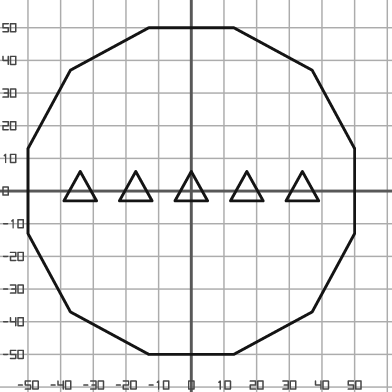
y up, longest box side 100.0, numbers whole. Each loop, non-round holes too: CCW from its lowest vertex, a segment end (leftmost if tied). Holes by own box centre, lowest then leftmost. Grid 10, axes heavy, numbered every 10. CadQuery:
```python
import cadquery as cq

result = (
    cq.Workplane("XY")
    .moveTo(-13.0, -50.0)
    .lineTo(13.0, -50.0)
    .lineTo(37.0, -37.0)
    .lineTo(50.0, -13.0)
    .lineTo(50.0, 13.0)
    .lineTo(37.0, 37.0)
    .lineTo(13.0, 50.0)
    .lineTo(-13.0, 50.0)
    .lineTo(-37.0, 37.0)
    .lineTo(-50.0, 13.0)
    .lineTo(-50.0, -13.0)
    .lineTo(-37.0, -37.0)
    .close()
    .moveTo(-39.0, -3.0)
    .lineTo(-29.0, -3.0)
    .lineTo(-34.0, 6.0)
    .close()
    .moveTo(-22.0, -3.0)
    .lineTo(-12.0, -3.0)
    .lineTo(-17.0, 6.0)
    .close()
    .moveTo(-5.0, -3.0)
    .lineTo(5.0, -3.0)
    .lineTo(0.0, 6.0)
    .close()
    .moveTo(12.0, -3.0)
    .lineTo(22.0, -3.0)
    .lineTo(17.0, 6.0)
    .close()
    .moveTo(29.0, -3.0)
    .lineTo(39.0, -3.0)
    .lineTo(34.0, 6.0)
    .close()
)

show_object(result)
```